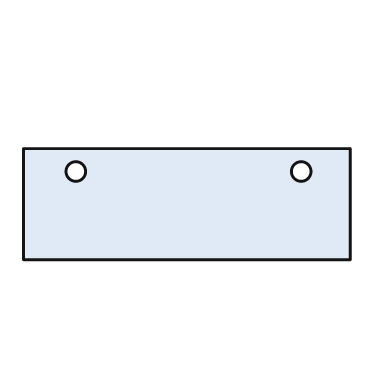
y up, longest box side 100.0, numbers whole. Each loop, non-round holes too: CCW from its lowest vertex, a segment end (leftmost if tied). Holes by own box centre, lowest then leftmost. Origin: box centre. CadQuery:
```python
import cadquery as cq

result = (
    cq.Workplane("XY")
    .moveTo(-50.0, -17.0)
    .lineTo(50.0, -17.0)
    .lineTo(50.0, 17.0)
    .lineTo(-50.0, 17.0)
    .close()
    .moveTo(-34.0, 10.0)
    .circle(3.0)
    .moveTo(35.0, 10.0)
    .circle(3.0)
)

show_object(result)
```